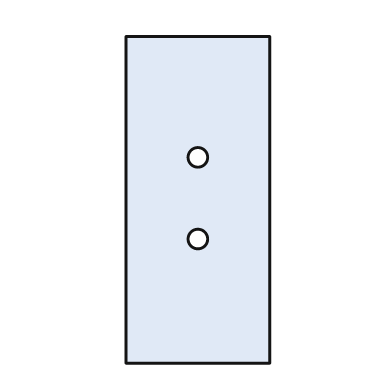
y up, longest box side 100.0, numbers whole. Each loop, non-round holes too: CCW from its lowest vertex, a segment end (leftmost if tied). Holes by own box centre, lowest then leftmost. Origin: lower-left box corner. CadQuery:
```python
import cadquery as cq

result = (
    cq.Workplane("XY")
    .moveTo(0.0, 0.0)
    .lineTo(44.0, 0.0)
    .lineTo(44.0, 100.0)
    .lineTo(0.0, 100.0)
    .close()
    .moveTo(22.0, 38.0)
    .circle(3.0)
    .moveTo(22.0, 63.0)
    .circle(3.0)
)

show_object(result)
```